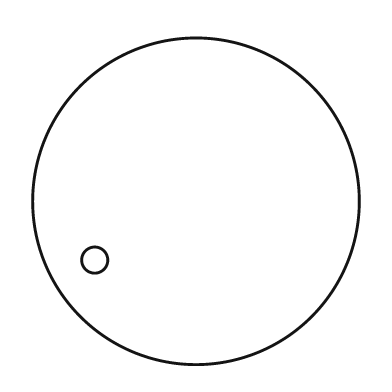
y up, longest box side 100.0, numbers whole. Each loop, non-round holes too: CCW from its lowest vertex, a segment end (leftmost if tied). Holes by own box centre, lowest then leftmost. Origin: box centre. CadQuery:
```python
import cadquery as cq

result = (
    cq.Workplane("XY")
    .moveTo(0.0, 0.0)
    .circle(50.0)
    .moveTo(-31.0, -18.0)
    .circle(4.0)
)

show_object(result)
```